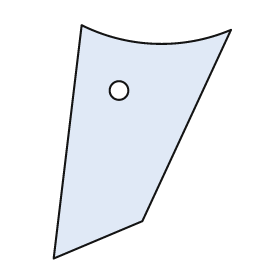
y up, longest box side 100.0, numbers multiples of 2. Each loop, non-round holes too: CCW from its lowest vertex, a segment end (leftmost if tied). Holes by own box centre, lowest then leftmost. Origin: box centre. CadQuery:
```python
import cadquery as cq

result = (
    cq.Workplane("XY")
    .moveTo(-38.0, -50.0)
    .lineTo(0.0, -34.0)
    .lineTo(38.0, 48.0)
    .threePointArc((6.0, 42.0), (-26.0, 50.0))
    .close()
    .moveTo(-10.0, 22.0)
    .circle(4.0)
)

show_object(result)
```